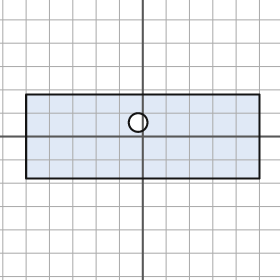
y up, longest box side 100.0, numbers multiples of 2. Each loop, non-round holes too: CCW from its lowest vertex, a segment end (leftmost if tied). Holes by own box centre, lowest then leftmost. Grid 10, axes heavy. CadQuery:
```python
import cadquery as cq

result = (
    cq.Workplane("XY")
    .moveTo(-50.0, -18.0)
    .lineTo(50.0, -18.0)
    .lineTo(50.0, 18.0)
    .lineTo(-50.0, 18.0)
    .close()
    .moveTo(-2.0, 6.0)
    .circle(4.0)
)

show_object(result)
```